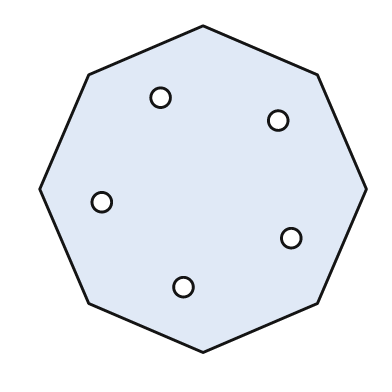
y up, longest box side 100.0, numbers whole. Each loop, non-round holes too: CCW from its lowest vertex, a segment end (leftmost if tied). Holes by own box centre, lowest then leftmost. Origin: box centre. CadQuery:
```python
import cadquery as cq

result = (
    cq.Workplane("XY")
    .moveTo(0.0, -50.0)
    .lineTo(35.0, -35.0)
    .lineTo(50.0, 0.0)
    .lineTo(35.0, 35.0)
    .lineTo(0.0, 50.0)
    .lineTo(-35.0, 35.0)
    .lineTo(-50.0, 0.0)
    .lineTo(-35.0, -35.0)
    .close()
    .moveTo(-6.0, -30.0)
    .circle(3.0)
    .moveTo(27.0, -15.0)
    .circle(3.0)
    .moveTo(-31.0, -4.0)
    .circle(3.0)
    .moveTo(23.0, 21.0)
    .circle(3.0)
    .moveTo(-13.0, 28.0)
    .circle(3.0)
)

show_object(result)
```